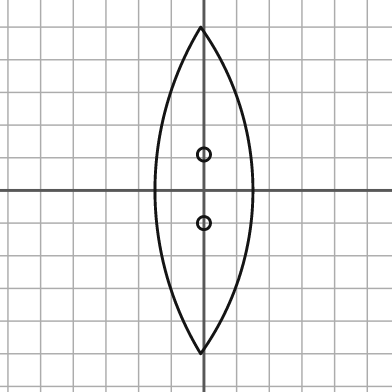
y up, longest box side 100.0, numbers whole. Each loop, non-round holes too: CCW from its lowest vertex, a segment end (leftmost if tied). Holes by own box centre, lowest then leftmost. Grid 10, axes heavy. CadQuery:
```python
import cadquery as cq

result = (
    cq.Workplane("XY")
    .moveTo(-1.0, -50.0)
    .threePointArc((15.0, 0.0), (-1.0, 50.0))
    .threePointArc((-15.0, 0.0), (-1.0, -50.0))
    .close()
    .moveTo(0.0, -10.0)
    .circle(2.0)
    .moveTo(0.0, 11.0)
    .circle(2.0)
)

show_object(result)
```